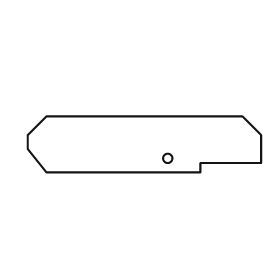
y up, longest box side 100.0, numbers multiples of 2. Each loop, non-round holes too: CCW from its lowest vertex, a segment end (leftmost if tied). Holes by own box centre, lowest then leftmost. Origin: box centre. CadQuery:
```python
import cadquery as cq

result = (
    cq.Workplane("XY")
    .moveTo(-42.0, -12.0)
    .lineTo(24.0, -12.0)
    .lineTo(24.0, -8.0)
    .lineTo(50.0, -8.0)
    .lineTo(50.0, 4.0)
    .lineTo(42.0, 12.0)
    .lineTo(-42.0, 12.0)
    .lineTo(-50.0, 4.0)
    .lineTo(-50.0, -2.0)
    .close()
    .moveTo(10.0, -6.0)
    .circle(2.0)
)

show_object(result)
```